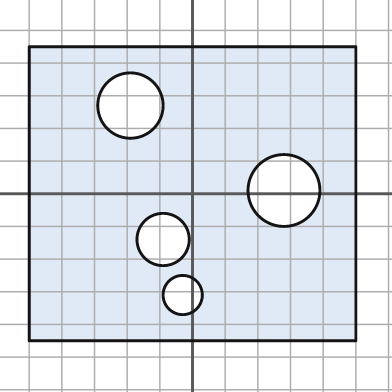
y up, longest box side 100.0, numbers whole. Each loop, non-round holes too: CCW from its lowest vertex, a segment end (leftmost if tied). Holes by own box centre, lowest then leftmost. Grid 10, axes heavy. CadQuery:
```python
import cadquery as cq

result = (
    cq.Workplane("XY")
    .moveTo(-50.0, -45.0)
    .lineTo(50.0, -45.0)
    .lineTo(50.0, 45.0)
    .lineTo(-50.0, 45.0)
    .close()
    .moveTo(-3.0, -31.0)
    .circle(6.0)
    .moveTo(-9.0, -14.0)
    .circle(8.0)
    .moveTo(28.0, 1.0)
    .circle(11.0)
    .moveTo(-19.0, 27.0)
    .circle(10.0)
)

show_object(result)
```